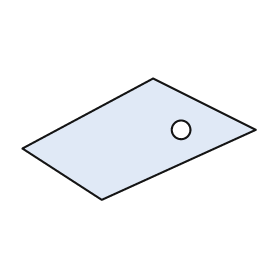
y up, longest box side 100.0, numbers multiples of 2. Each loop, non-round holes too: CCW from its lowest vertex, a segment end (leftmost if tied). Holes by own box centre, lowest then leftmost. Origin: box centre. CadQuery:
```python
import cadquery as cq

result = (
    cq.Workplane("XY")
    .moveTo(-16.0, -26.0)
    .lineTo(50.0, 4.0)
    .lineTo(6.0, 26.0)
    .lineTo(-50.0, -4.0)
    .close()
    .moveTo(18.0, 4.0)
    .circle(4.0)
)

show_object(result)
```